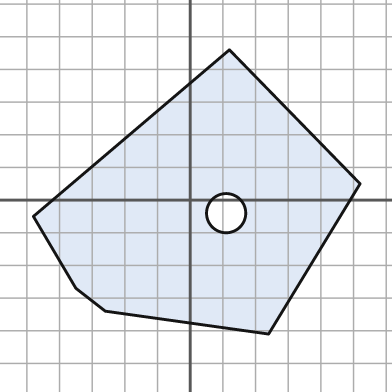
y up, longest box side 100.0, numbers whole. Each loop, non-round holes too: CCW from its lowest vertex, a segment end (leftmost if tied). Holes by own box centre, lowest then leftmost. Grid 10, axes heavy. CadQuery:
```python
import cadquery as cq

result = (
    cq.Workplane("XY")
    .moveTo(24.0, -41.0)
    .lineTo(52.0, 5.0)
    .lineTo(12.0, 46.0)
    .lineTo(-48.0, -5.0)
    .lineTo(-35.0, -27.0)
    .lineTo(-26.0, -34.0)
    .close()
    .moveTo(11.0, -4.0)
    .circle(6.0)
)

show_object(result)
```